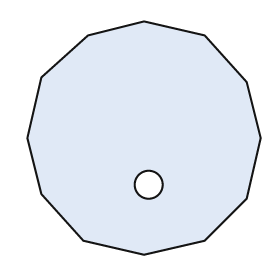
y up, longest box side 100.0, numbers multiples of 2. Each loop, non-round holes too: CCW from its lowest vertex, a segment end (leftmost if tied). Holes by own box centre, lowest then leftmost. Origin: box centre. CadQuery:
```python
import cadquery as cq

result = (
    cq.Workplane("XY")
    .moveTo(0.0, -50.0)
    .lineTo(26.0, -44.0)
    .lineTo(44.0, -26.0)
    .lineTo(50.0, 0.0)
    .lineTo(44.0, 24.0)
    .lineTo(26.0, 44.0)
    .lineTo(0.0, 50.0)
    .lineTo(-24.0, 44.0)
    .lineTo(-44.0, 26.0)
    .lineTo(-50.0, 0.0)
    .lineTo(-44.0, -24.0)
    .lineTo(-26.0, -44.0)
    .close()
    .moveTo(2.0, -20.0)
    .circle(6.0)
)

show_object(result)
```